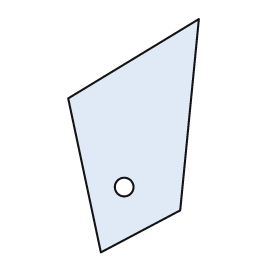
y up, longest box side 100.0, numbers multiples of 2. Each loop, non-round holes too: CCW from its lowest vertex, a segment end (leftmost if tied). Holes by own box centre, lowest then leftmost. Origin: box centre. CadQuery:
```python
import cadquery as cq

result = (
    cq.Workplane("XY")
    .moveTo(-14.0, -50.0)
    .lineTo(20.0, -32.0)
    .lineTo(28.0, 50.0)
    .lineTo(-28.0, 16.0)
    .close()
    .moveTo(-4.0, -22.0)
    .circle(4.0)
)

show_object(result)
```